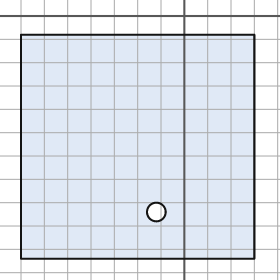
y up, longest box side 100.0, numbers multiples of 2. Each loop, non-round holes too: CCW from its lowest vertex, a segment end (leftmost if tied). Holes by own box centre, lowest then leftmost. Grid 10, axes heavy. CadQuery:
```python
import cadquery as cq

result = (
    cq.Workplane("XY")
    .moveTo(-70.0, -104.0)
    .lineTo(30.0, -104.0)
    .lineTo(30.0, -8.0)
    .lineTo(-70.0, -8.0)
    .close()
    .moveTo(-12.0, -84.0)
    .circle(4.0)
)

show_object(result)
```